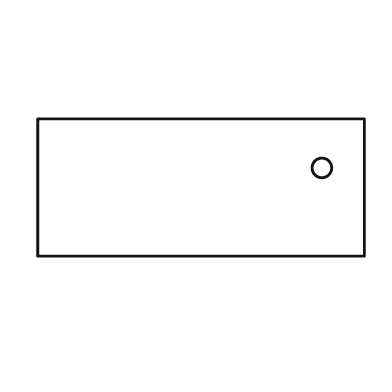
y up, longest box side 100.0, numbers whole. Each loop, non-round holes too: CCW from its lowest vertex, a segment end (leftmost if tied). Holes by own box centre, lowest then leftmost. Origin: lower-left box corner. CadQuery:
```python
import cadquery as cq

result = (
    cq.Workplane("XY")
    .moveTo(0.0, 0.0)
    .lineTo(100.0, 0.0)
    .lineTo(100.0, 42.0)
    .lineTo(0.0, 42.0)
    .close()
    .moveTo(87.0, 27.0)
    .circle(3.0)
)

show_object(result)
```